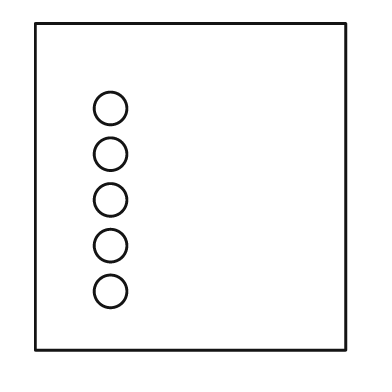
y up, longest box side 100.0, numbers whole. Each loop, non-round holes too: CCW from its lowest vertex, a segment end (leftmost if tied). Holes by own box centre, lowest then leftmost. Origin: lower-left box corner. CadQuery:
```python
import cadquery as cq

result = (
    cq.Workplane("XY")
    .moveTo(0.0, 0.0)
    .lineTo(95.0, 0.0)
    .lineTo(95.0, 100.0)
    .lineTo(0.0, 100.0)
    .close()
    .moveTo(23.0, 18.0)
    .circle(5.0)
    .moveTo(23.0, 32.0)
    .circle(5.0)
    .moveTo(23.0, 46.0)
    .circle(5.0)
    .moveTo(23.0, 60.0)
    .circle(5.0)
    .moveTo(23.0, 74.0)
    .circle(5.0)
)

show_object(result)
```